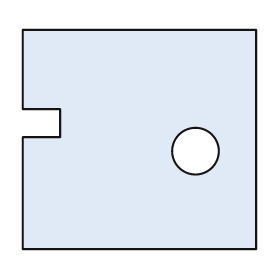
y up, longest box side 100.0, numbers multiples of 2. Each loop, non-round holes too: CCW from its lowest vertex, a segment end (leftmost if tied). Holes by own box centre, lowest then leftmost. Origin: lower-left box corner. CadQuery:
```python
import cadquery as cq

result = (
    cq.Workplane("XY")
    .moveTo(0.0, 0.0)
    .lineTo(100.0, 0.0)
    .lineTo(100.0, 94.0)
    .lineTo(0.0, 94.0)
    .lineTo(0.0, 60.0)
    .lineTo(16.0, 60.0)
    .lineTo(16.0, 48.0)
    .lineTo(0.0, 48.0)
    .close()
    .moveTo(74.0, 42.0)
    .circle(10.0)
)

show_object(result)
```